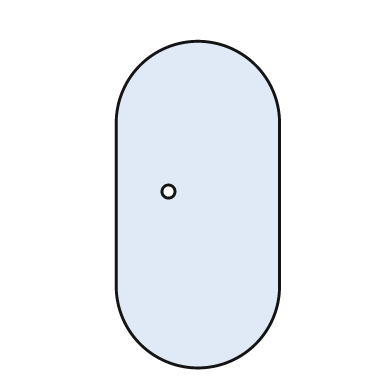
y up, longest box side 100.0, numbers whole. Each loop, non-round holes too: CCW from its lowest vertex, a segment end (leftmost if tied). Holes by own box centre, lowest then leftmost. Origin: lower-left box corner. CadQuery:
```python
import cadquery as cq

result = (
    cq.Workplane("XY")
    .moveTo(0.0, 25.0)
    .threePointArc((25.0, 0.0), (50.0, 25.0))
    .lineTo(50.0, 75.0)
    .threePointArc((25.0, 100.0), (0.0, 75.0))
    .close()
    .moveTo(16.0, 54.0)
    .circle(2.0)
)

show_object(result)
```